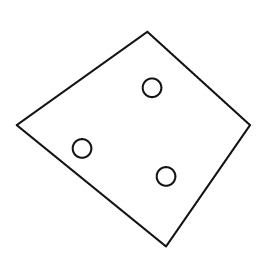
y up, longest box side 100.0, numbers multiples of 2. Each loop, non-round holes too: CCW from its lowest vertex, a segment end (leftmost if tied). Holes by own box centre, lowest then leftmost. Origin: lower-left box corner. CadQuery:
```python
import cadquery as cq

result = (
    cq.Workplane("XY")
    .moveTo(64.0, 0.0)
    .lineTo(100.0, 52.0)
    .lineTo(56.0, 92.0)
    .lineTo(0.0, 52.0)
    .close()
    .moveTo(64.0, 30.0)
    .circle(4.0)
    .moveTo(28.0, 42.0)
    .circle(4.0)
    .moveTo(58.0, 68.0)
    .circle(4.0)
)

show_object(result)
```